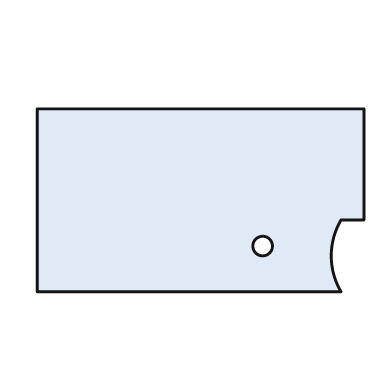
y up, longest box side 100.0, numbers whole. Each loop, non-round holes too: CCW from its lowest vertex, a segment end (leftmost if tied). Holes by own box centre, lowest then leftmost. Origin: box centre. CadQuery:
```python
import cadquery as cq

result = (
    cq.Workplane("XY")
    .moveTo(-50.0, -28.0)
    .lineTo(43.0, -28.0)
    .threePointArc((40.0, -17.0), (43.0, -6.0))
    .lineTo(50.0, -6.0)
    .lineTo(50.0, 28.0)
    .lineTo(-50.0, 28.0)
    .close()
    .moveTo(19.0, -14.0)
    .circle(3.0)
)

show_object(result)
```